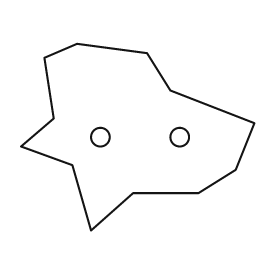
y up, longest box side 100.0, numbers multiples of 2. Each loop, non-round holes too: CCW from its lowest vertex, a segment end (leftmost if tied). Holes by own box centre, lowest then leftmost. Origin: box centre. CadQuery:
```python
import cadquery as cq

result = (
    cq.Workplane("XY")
    .moveTo(-20.0, -40.0)
    .lineTo(-2.0, -24.0)
    .lineTo(26.0, -24.0)
    .lineTo(42.0, -14.0)
    .lineTo(50.0, 6.0)
    .lineTo(14.0, 20.0)
    .lineTo(4.0, 36.0)
    .lineTo(-26.0, 40.0)
    .lineTo(-40.0, 34.0)
    .lineTo(-36.0, 8.0)
    .lineTo(-50.0, -4.0)
    .lineTo(-28.0, -12.0)
    .close()
    .moveTo(-16.0, 0.0)
    .circle(4.0)
    .moveTo(18.0, 0.0)
    .circle(4.0)
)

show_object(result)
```